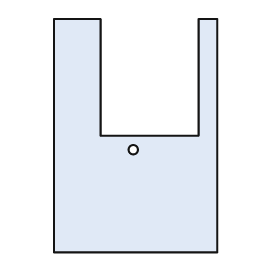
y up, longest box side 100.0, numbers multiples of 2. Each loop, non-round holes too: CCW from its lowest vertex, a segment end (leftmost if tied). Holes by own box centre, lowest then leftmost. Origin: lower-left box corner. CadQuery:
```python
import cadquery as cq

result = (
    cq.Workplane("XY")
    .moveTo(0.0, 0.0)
    .lineTo(70.0, 0.0)
    .lineTo(70.0, 100.0)
    .lineTo(62.0, 100.0)
    .lineTo(62.0, 50.0)
    .lineTo(20.0, 50.0)
    .lineTo(20.0, 100.0)
    .lineTo(0.0, 100.0)
    .close()
    .moveTo(34.0, 44.0)
    .circle(2.0)
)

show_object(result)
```